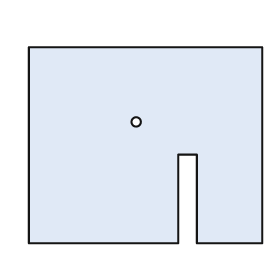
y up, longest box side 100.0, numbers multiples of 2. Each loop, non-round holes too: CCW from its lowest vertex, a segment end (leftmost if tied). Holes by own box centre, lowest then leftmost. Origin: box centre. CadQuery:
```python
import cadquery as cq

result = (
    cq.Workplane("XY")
    .moveTo(-50.0, -42.0)
    .lineTo(14.0, -42.0)
    .lineTo(14.0, -4.0)
    .lineTo(22.0, -4.0)
    .lineTo(22.0, -42.0)
    .lineTo(50.0, -42.0)
    .lineTo(50.0, 42.0)
    .lineTo(-50.0, 42.0)
    .close()
    .moveTo(-4.0, 10.0)
    .circle(2.0)
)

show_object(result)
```